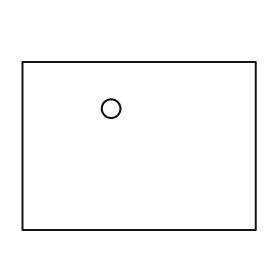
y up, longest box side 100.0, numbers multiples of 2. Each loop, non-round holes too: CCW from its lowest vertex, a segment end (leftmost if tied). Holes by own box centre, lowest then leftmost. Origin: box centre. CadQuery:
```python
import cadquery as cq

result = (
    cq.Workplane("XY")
    .moveTo(-50.0, -36.0)
    .lineTo(50.0, -36.0)
    .lineTo(50.0, 36.0)
    .lineTo(-50.0, 36.0)
    .close()
    .moveTo(-12.0, 16.0)
    .circle(4.0)
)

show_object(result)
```